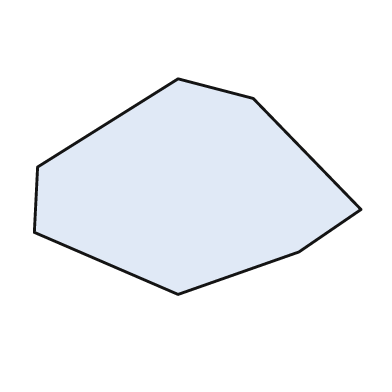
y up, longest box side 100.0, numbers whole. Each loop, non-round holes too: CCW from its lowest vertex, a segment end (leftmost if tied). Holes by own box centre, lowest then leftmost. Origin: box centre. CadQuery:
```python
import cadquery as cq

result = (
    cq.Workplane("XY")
    .moveTo(-6.0, -33.0)
    .lineTo(31.0, -20.0)
    .lineTo(50.0, -7.0)
    .lineTo(17.0, 27.0)
    .lineTo(-6.0, 33.0)
    .lineTo(-49.0, 6.0)
    .lineTo(-50.0, -14.0)
    .close()
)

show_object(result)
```